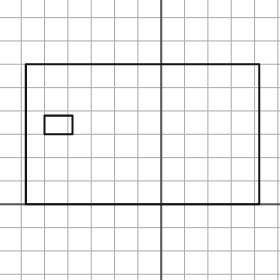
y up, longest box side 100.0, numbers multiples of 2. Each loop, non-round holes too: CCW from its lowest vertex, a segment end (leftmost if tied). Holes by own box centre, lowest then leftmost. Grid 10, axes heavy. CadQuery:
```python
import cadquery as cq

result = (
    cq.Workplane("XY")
    .moveTo(-58.0, 0.0)
    .lineTo(42.0, 0.0)
    .lineTo(42.0, 60.0)
    .lineTo(-58.0, 60.0)
    .close()
    .moveTo(-50.0, 30.0)
    .lineTo(-38.0, 30.0)
    .lineTo(-38.0, 38.0)
    .lineTo(-50.0, 38.0)
    .close()
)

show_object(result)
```